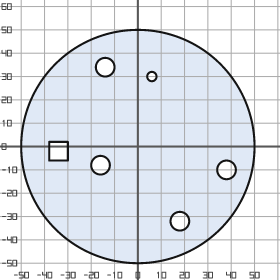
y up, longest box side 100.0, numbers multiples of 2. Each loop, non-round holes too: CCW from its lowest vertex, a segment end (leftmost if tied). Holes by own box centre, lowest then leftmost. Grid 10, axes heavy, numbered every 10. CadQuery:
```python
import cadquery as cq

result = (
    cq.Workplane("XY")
    .moveTo(0.0, 0.0)
    .circle(50.0)
    .moveTo(18.0, -32.0)
    .circle(4.0)
    .moveTo(38.0, -10.0)
    .circle(4.0)
    .moveTo(-16.0, -8.0)
    .circle(4.0)
    .moveTo(-38.0, -6.0)
    .lineTo(-30.0, -6.0)
    .lineTo(-30.0, 2.0)
    .lineTo(-38.0, 2.0)
    .close()
    .moveTo(6.0, 30.0)
    .circle(2.0)
    .moveTo(-14.0, 34.0)
    .circle(4.0)
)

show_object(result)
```